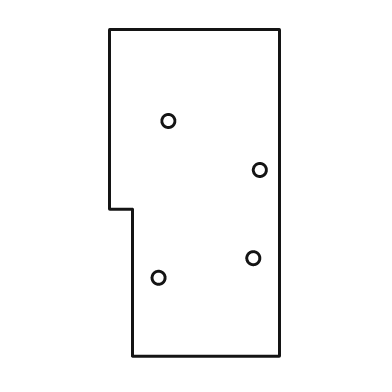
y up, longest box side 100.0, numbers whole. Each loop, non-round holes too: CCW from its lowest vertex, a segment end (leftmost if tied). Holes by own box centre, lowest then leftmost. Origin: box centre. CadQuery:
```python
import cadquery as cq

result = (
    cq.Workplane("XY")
    .moveTo(-19.0, -50.0)
    .lineTo(26.0, -50.0)
    .lineTo(26.0, 50.0)
    .lineTo(-26.0, 50.0)
    .lineTo(-26.0, -5.0)
    .lineTo(-19.0, -5.0)
    .close()
    .moveTo(-11.0, -26.0)
    .circle(2.0)
    .moveTo(18.0, -20.0)
    .circle(2.0)
    .moveTo(20.0, 7.0)
    .circle(2.0)
    .moveTo(-8.0, 22.0)
    .circle(2.0)
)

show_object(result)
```